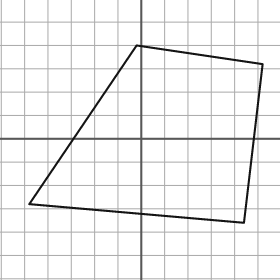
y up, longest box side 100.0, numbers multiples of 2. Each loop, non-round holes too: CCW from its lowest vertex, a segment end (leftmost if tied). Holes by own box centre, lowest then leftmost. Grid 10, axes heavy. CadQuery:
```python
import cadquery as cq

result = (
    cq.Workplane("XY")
    .moveTo(44.0, -36.0)
    .lineTo(52.0, 32.0)
    .lineTo(-2.0, 40.0)
    .lineTo(-48.0, -28.0)
    .close()
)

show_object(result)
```